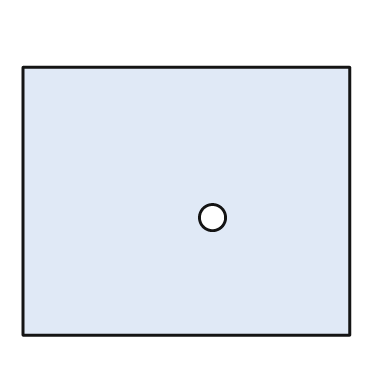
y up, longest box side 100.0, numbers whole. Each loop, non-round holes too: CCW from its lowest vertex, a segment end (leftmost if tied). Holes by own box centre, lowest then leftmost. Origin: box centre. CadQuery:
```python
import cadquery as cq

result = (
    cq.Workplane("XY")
    .moveTo(-50.0, -41.0)
    .lineTo(50.0, -41.0)
    .lineTo(50.0, 41.0)
    .lineTo(-50.0, 41.0)
    .close()
    .moveTo(8.0, -5.0)
    .circle(4.0)
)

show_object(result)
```